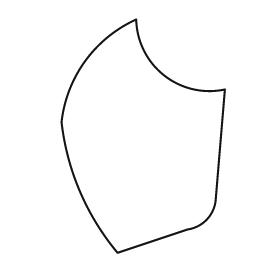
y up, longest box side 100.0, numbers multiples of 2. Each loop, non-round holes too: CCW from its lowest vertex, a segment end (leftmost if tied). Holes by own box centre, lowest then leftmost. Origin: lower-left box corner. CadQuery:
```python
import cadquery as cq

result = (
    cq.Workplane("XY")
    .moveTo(24.0, 0.0)
    .lineTo(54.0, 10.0)
    .threePointArc((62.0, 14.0), (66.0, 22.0))
    .lineTo(70.0, 70.0)
    .threePointArc((44.0, 76.0), (32.0, 100.0))
    .threePointArc((10.0, 82.0), (0.0, 56.0))
    .threePointArc((8.0, 26.0), (24.0, 0.0))
    .close()
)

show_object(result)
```